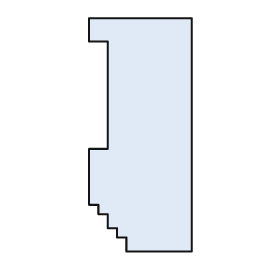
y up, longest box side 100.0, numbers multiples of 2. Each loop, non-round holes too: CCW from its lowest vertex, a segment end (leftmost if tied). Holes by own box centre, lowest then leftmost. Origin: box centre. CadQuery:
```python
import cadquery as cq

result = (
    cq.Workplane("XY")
    .moveTo(-6.0, -50.0)
    .lineTo(22.0, -50.0)
    .lineTo(22.0, 50.0)
    .lineTo(-22.0, 50.0)
    .lineTo(-22.0, 40.0)
    .lineTo(-14.0, 40.0)
    .lineTo(-14.0, -6.0)
    .lineTo(-22.0, -6.0)
    .lineTo(-22.0, -30.0)
    .lineTo(-18.0, -30.0)
    .lineTo(-18.0, -34.0)
    .lineTo(-14.0, -34.0)
    .lineTo(-14.0, -40.0)
    .lineTo(-10.0, -40.0)
    .lineTo(-10.0, -44.0)
    .lineTo(-6.0, -44.0)
    .close()
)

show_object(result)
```